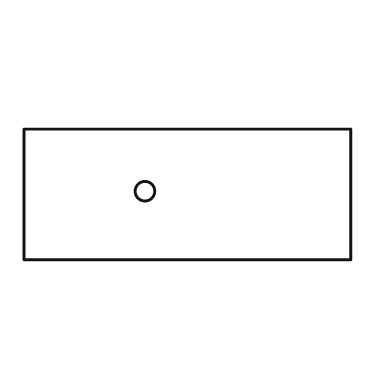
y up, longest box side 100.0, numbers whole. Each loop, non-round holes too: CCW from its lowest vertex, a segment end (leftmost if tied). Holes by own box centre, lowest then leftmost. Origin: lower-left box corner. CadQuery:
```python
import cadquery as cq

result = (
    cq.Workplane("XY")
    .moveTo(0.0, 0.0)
    .lineTo(100.0, 0.0)
    .lineTo(100.0, 40.0)
    .lineTo(0.0, 40.0)
    .close()
    .moveTo(37.0, 21.0)
    .circle(3.0)
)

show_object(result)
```